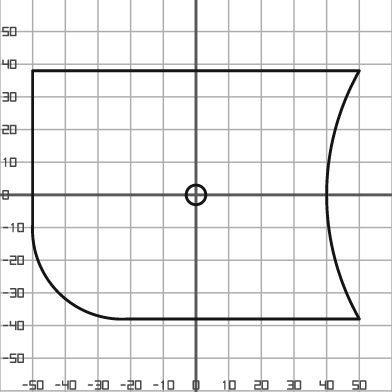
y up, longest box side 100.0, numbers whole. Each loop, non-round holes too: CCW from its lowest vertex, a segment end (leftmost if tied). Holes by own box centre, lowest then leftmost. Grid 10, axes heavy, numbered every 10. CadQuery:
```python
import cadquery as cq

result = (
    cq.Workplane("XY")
    .moveTo(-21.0, -38.0)
    .lineTo(50.0, -38.0)
    .threePointArc((40.0, 0.0), (50.0, 38.0))
    .lineTo(-50.0, 38.0)
    .lineTo(-50.0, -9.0)
    .threePointArc((-42.0, -30.0), (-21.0, -38.0))
    .close()
    .moveTo(0.0, 0.0)
    .circle(3.0)
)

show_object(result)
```